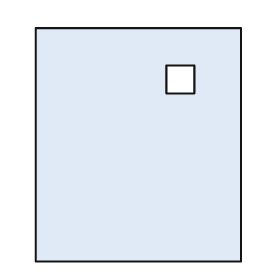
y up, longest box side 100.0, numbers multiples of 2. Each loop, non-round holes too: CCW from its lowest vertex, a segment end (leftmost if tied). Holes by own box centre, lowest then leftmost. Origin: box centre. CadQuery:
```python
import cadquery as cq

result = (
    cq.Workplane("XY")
    .moveTo(-44.0, -50.0)
    .lineTo(44.0, -50.0)
    .lineTo(44.0, 50.0)
    .lineTo(-44.0, 50.0)
    .close()
    .moveTo(12.0, 22.0)
    .lineTo(24.0, 22.0)
    .lineTo(24.0, 34.0)
    .lineTo(12.0, 34.0)
    .close()
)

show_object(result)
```